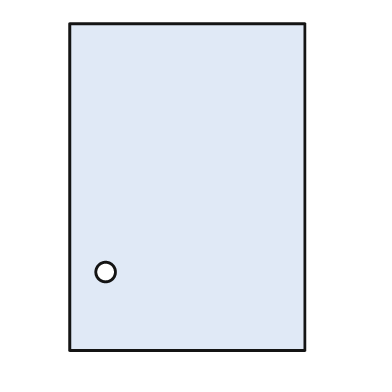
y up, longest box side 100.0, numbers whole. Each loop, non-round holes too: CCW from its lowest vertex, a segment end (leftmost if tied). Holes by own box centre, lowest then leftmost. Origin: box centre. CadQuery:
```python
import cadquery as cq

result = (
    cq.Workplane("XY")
    .moveTo(-36.0, -50.0)
    .lineTo(36.0, -50.0)
    .lineTo(36.0, 50.0)
    .lineTo(-36.0, 50.0)
    .close()
    .moveTo(-25.0, -26.0)
    .circle(3.0)
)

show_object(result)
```